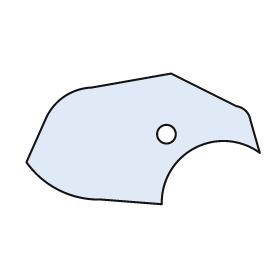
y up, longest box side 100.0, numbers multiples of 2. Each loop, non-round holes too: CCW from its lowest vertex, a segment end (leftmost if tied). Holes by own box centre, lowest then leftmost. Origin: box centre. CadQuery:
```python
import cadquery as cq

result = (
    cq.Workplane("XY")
    .moveTo(8.0, -28.0)
    .threePointArc((22.0, -4.0), (50.0, -6.0))
    .lineTo(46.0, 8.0)
    .threePointArc((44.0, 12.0), (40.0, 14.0))
    .lineTo(12.0, 28.0)
    .lineTo(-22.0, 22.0)
    .threePointArc((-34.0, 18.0), (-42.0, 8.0))
    .lineTo(-50.0, -10.0)
    .threePointArc((-36.0, -22.0), (-18.0, -26.0))
    .close()
    .moveTo(10.0, 2.0)
    .circle(4.0)
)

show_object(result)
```